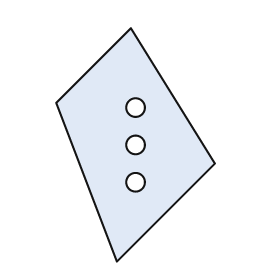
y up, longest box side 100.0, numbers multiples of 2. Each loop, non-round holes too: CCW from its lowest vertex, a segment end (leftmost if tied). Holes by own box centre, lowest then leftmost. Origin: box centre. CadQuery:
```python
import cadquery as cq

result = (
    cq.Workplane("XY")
    .moveTo(-8.0, -50.0)
    .lineTo(34.0, -8.0)
    .lineTo(-2.0, 50.0)
    .lineTo(-34.0, 18.0)
    .close()
    .moveTo(0.0, -16.0)
    .circle(4.0)
    .moveTo(0.0, 0.0)
    .circle(4.0)
    .moveTo(0.0, 16.0)
    .circle(4.0)
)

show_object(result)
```